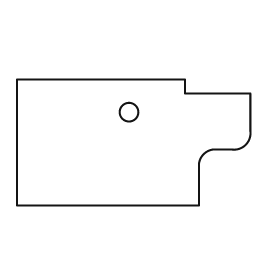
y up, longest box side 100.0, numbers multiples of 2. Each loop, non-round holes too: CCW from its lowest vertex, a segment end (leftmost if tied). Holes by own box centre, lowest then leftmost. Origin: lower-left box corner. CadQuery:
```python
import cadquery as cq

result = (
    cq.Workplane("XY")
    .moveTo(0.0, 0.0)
    .lineTo(78.0, 0.0)
    .lineTo(78.0, 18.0)
    .threePointArc((80.0, 22.0), (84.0, 24.0))
    .lineTo(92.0, 24.0)
    .threePointArc((98.0, 26.0), (100.0, 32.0))
    .lineTo(100.0, 48.0)
    .lineTo(72.0, 48.0)
    .lineTo(72.0, 54.0)
    .lineTo(0.0, 54.0)
    .close()
    .moveTo(48.0, 40.0)
    .circle(4.0)
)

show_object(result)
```